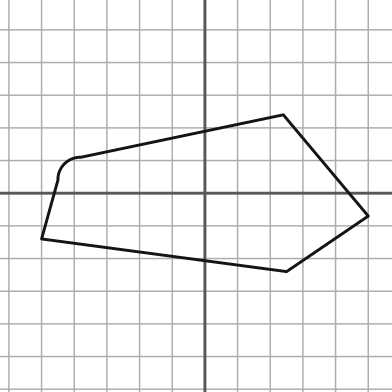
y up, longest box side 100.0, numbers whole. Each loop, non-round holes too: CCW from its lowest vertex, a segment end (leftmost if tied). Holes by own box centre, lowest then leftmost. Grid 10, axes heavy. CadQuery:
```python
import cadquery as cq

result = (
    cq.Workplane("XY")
    .moveTo(25.0, -24.0)
    .lineTo(50.0, -7.0)
    .lineTo(24.0, 24.0)
    .lineTo(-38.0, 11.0)
    .threePointArc((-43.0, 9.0), (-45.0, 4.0))
    .lineTo(-50.0, -14.0)
    .close()
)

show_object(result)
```